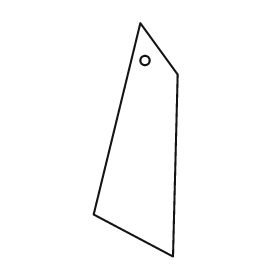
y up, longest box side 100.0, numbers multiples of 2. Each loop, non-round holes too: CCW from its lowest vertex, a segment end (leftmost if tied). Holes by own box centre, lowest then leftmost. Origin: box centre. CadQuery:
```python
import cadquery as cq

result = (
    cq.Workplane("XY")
    .moveTo(16.0, -50.0)
    .lineTo(18.0, 28.0)
    .lineTo(2.0, 50.0)
    .lineTo(-18.0, -32.0)
    .close()
    .moveTo(4.0, 34.0)
    .circle(2.0)
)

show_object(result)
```